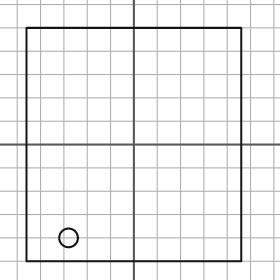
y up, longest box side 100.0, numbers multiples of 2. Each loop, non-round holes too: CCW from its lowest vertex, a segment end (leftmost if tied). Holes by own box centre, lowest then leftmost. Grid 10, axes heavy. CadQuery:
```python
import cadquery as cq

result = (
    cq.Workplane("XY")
    .moveTo(-46.0, -50.0)
    .lineTo(46.0, -50.0)
    .lineTo(46.0, 50.0)
    .lineTo(-46.0, 50.0)
    .close()
    .moveTo(-28.0, -40.0)
    .circle(4.0)
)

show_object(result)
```